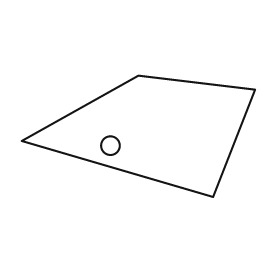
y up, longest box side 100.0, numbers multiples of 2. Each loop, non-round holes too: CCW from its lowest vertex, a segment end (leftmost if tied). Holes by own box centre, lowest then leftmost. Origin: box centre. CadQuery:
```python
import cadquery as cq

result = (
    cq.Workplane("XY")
    .moveTo(32.0, -26.0)
    .lineTo(50.0, 20.0)
    .lineTo(0.0, 26.0)
    .lineTo(-50.0, -2.0)
    .close()
    .moveTo(-12.0, -4.0)
    .circle(4.0)
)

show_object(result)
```